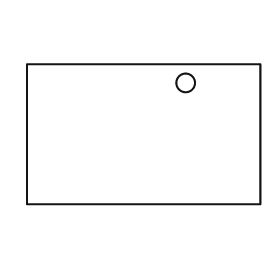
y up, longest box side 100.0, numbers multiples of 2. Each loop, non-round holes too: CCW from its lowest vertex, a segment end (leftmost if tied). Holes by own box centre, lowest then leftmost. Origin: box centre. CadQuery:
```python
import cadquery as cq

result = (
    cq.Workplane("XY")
    .moveTo(-50.0, -30.0)
    .lineTo(50.0, -30.0)
    .lineTo(50.0, 30.0)
    .lineTo(-50.0, 30.0)
    .close()
    .moveTo(18.0, 22.0)
    .circle(4.0)
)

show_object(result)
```